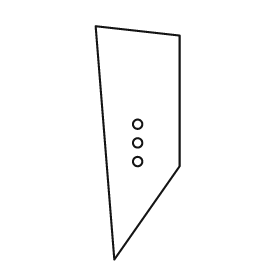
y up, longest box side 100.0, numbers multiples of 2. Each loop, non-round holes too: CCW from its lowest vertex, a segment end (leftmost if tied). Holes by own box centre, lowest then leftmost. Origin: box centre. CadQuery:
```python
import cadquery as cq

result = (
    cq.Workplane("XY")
    .moveTo(-10.0, -50.0)
    .lineTo(18.0, -10.0)
    .lineTo(18.0, 46.0)
    .lineTo(-18.0, 50.0)
    .close()
    .moveTo(0.0, -8.0)
    .circle(2.0)
    .moveTo(0.0, 0.0)
    .circle(2.0)
    .moveTo(0.0, 8.0)
    .circle(2.0)
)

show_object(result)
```